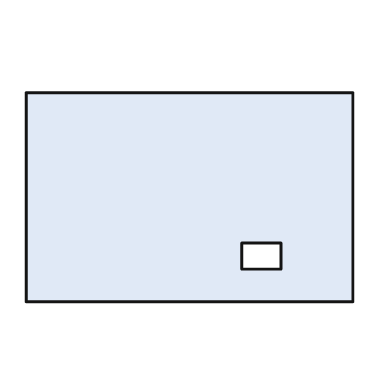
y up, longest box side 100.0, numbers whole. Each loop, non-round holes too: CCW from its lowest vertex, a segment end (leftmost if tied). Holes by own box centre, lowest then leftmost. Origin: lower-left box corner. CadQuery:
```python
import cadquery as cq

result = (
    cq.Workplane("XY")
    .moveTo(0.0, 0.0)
    .lineTo(100.0, 0.0)
    .lineTo(100.0, 64.0)
    .lineTo(0.0, 64.0)
    .close()
    .moveTo(66.0, 10.0)
    .lineTo(78.0, 10.0)
    .lineTo(78.0, 18.0)
    .lineTo(66.0, 18.0)
    .close()
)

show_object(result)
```